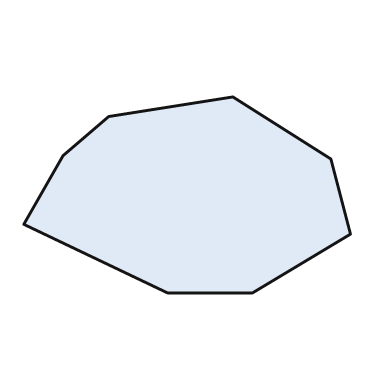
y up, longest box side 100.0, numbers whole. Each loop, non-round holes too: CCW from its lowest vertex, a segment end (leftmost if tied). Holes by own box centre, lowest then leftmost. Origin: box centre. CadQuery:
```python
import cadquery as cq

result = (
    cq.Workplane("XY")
    .moveTo(-6.0, -30.0)
    .lineTo(20.0, -30.0)
    .lineTo(50.0, -12.0)
    .lineTo(44.0, 11.0)
    .lineTo(14.0, 30.0)
    .lineTo(-24.0, 24.0)
    .lineTo(-38.0, 12.0)
    .lineTo(-50.0, -9.0)
    .close()
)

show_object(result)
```